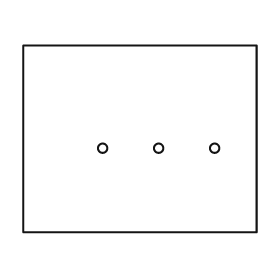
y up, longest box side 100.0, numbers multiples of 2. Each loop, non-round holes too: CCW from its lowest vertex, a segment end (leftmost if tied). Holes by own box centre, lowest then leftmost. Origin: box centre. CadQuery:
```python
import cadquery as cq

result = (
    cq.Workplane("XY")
    .moveTo(-50.0, -40.0)
    .lineTo(50.0, -40.0)
    .lineTo(50.0, 40.0)
    .lineTo(-50.0, 40.0)
    .close()
    .moveTo(-16.0, -4.0)
    .circle(2.0)
    .moveTo(8.0, -4.0)
    .circle(2.0)
    .moveTo(32.0, -4.0)
    .circle(2.0)
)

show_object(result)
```